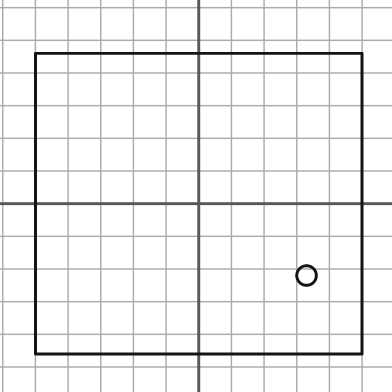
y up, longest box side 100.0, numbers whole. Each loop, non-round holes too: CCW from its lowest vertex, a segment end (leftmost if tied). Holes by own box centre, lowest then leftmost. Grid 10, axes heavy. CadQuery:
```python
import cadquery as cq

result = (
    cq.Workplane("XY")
    .moveTo(-50.0, -46.0)
    .lineTo(50.0, -46.0)
    .lineTo(50.0, 46.0)
    .lineTo(-50.0, 46.0)
    .close()
    .moveTo(33.0, -22.0)
    .circle(3.0)
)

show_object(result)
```